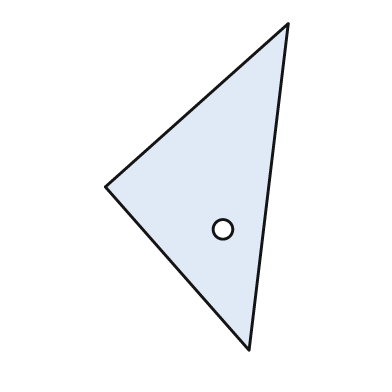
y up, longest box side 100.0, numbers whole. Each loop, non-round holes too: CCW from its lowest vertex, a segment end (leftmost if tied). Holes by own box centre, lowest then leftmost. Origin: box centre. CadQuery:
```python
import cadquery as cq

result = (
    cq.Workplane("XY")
    .moveTo(16.0, -50.0)
    .lineTo(28.0, 50.0)
    .lineTo(-28.0, 0.0)
    .close()
    .moveTo(8.0, -13.0)
    .circle(3.0)
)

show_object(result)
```